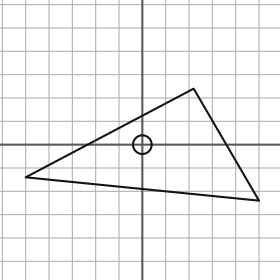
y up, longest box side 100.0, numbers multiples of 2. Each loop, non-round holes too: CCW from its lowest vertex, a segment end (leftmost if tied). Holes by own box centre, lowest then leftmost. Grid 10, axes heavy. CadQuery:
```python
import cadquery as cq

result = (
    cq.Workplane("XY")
    .moveTo(50.0, -24.0)
    .lineTo(22.0, 24.0)
    .lineTo(-50.0, -14.0)
    .close()
    .moveTo(0.0, 0.0)
    .circle(4.0)
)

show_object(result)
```